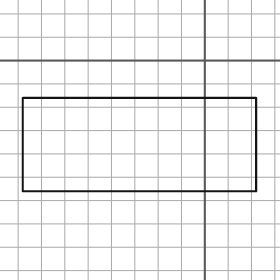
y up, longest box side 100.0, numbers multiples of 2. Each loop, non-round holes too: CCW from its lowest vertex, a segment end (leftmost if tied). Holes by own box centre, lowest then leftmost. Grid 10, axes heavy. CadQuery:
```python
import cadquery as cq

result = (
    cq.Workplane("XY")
    .moveTo(-78.0, -56.0)
    .lineTo(22.0, -56.0)
    .lineTo(22.0, -16.0)
    .lineTo(-78.0, -16.0)
    .close()
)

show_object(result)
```